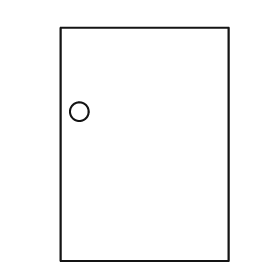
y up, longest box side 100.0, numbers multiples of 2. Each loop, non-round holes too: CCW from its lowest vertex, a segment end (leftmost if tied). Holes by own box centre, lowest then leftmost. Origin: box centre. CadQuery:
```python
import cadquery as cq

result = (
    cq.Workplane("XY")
    .moveTo(-36.0, -50.0)
    .lineTo(36.0, -50.0)
    .lineTo(36.0, 50.0)
    .lineTo(-36.0, 50.0)
    .close()
    .moveTo(-28.0, 14.0)
    .circle(4.0)
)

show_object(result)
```